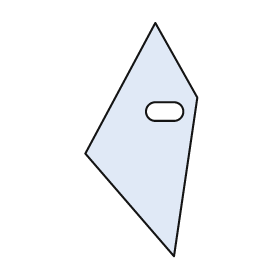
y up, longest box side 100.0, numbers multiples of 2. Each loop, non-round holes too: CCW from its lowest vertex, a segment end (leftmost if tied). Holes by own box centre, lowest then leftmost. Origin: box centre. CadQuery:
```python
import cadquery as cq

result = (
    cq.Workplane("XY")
    .moveTo(14.0, -50.0)
    .lineTo(24.0, 18.0)
    .lineTo(6.0, 50.0)
    .lineTo(-24.0, -6.0)
    .close()
    .moveTo(6.0, 8.0)
    .lineTo(14.0, 8.0)
    .threePointArc((18.0, 12.0), (14.0, 16.0))
    .lineTo(6.0, 16.0)
    .threePointArc((2.0, 12.0), (6.0, 8.0))
    .close()
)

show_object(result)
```